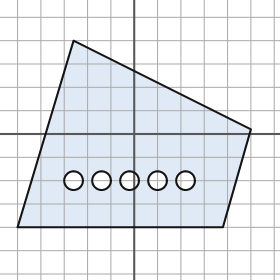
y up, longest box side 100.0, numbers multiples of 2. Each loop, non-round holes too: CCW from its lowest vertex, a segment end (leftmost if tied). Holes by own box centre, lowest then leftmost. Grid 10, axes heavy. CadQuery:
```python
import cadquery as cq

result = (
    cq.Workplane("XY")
    .moveTo(-50.0, -40.0)
    .lineTo(38.0, -40.0)
    .lineTo(50.0, 2.0)
    .lineTo(-26.0, 40.0)
    .close()
    .moveTo(-26.0, -20.0)
    .circle(4.0)
    .moveTo(-14.0, -20.0)
    .circle(4.0)
    .moveTo(-2.0, -20.0)
    .circle(4.0)
    .moveTo(10.0, -20.0)
    .circle(4.0)
    .moveTo(22.0, -20.0)
    .circle(4.0)
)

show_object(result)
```